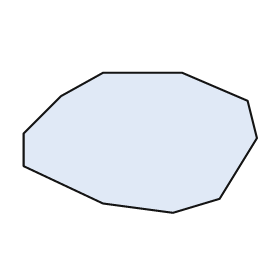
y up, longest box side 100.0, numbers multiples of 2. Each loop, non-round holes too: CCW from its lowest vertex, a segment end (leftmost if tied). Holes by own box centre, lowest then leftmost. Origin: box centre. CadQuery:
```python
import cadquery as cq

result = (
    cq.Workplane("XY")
    .moveTo(14.0, -30.0)
    .lineTo(34.0, -24.0)
    .lineTo(50.0, 2.0)
    .lineTo(46.0, 18.0)
    .lineTo(18.0, 30.0)
    .lineTo(-16.0, 30.0)
    .lineTo(-34.0, 20.0)
    .lineTo(-50.0, 4.0)
    .lineTo(-50.0, -10.0)
    .lineTo(-16.0, -26.0)
    .close()
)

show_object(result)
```